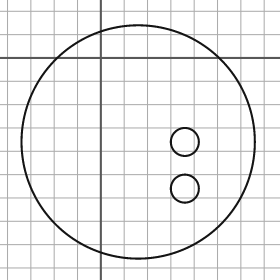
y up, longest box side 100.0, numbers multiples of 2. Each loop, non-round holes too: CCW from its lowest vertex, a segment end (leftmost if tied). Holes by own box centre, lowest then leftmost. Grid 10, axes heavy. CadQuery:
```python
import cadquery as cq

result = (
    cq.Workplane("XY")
    .moveTo(16.0, -36.0)
    .circle(50.0)
    .moveTo(36.0, -56.0)
    .circle(6.0)
    .moveTo(36.0, -36.0)
    .circle(6.0)
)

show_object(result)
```